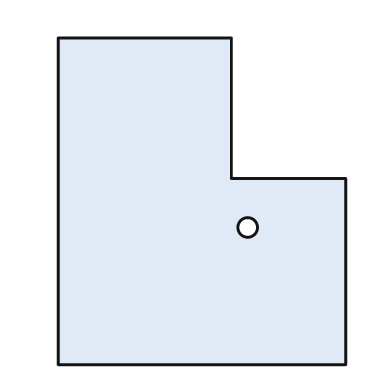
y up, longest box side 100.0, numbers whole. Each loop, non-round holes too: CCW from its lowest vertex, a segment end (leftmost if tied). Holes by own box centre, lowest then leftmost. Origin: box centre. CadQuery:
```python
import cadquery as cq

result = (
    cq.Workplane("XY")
    .moveTo(-44.0, -50.0)
    .lineTo(44.0, -50.0)
    .lineTo(44.0, 7.0)
    .lineTo(9.0, 7.0)
    .lineTo(9.0, 50.0)
    .lineTo(-44.0, 50.0)
    .close()
    .moveTo(14.0, -8.0)
    .circle(3.0)
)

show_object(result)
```